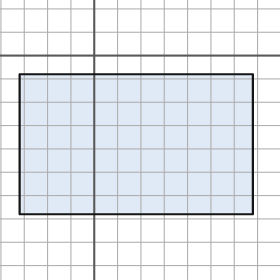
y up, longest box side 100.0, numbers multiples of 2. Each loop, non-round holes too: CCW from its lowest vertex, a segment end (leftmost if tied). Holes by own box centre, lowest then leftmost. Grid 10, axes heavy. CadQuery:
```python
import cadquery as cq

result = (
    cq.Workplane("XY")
    .moveTo(-32.0, -68.0)
    .lineTo(68.0, -68.0)
    .lineTo(68.0, -8.0)
    .lineTo(-32.0, -8.0)
    .close()
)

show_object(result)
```